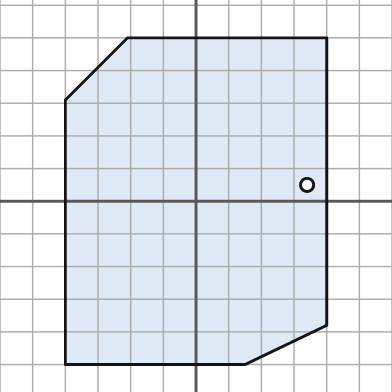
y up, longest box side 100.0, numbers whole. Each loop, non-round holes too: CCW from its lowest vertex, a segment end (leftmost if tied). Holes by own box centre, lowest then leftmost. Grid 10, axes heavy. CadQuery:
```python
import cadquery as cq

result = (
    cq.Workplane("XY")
    .moveTo(-40.0, -50.0)
    .lineTo(15.0, -50.0)
    .lineTo(40.0, -38.0)
    .lineTo(40.0, 50.0)
    .lineTo(-21.0, 50.0)
    .lineTo(-40.0, 31.0)
    .close()
    .moveTo(34.0, 5.0)
    .circle(2.0)
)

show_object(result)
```